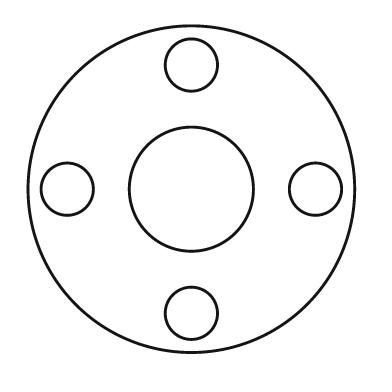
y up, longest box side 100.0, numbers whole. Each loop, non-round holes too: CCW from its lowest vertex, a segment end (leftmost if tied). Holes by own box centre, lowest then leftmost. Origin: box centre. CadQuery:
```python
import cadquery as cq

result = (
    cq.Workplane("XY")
    .moveTo(0.0, 0.0)
    .circle(50.0)
    .moveTo(0.0, -38.0)
    .circle(8.0)
    .moveTo(-38.0, 0.0)
    .circle(8.0)
    .moveTo(0.0, 0.0)
    .circle(19.0)
    .moveTo(38.0, 0.0)
    .circle(8.0)
    .moveTo(0.0, 38.0)
    .circle(8.0)
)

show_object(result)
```